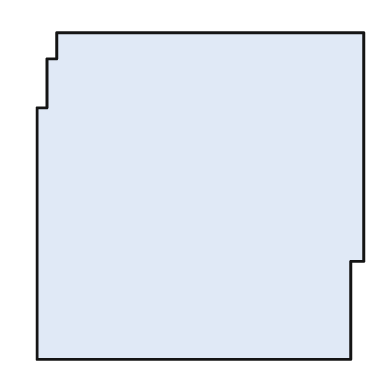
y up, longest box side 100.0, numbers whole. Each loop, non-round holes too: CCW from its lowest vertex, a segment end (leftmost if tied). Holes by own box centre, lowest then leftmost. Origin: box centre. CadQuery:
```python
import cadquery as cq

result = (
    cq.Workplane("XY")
    .moveTo(-50.0, -50.0)
    .lineTo(46.0, -50.0)
    .lineTo(46.0, -20.0)
    .lineTo(50.0, -20.0)
    .lineTo(50.0, 50.0)
    .lineTo(-44.0, 50.0)
    .lineTo(-44.0, 42.0)
    .lineTo(-47.0, 42.0)
    .lineTo(-47.0, 27.0)
    .lineTo(-50.0, 27.0)
    .close()
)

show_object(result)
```